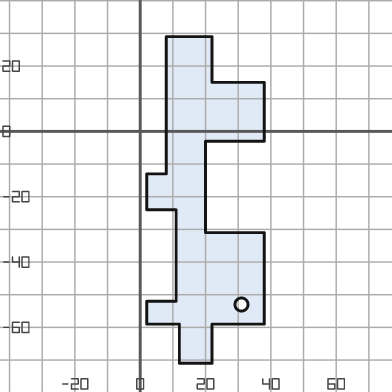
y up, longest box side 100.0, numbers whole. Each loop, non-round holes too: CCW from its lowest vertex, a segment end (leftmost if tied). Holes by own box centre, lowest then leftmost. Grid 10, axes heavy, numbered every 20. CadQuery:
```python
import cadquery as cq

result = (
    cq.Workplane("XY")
    .moveTo(12.0, -71.0)
    .lineTo(22.0, -71.0)
    .lineTo(22.0, -59.0)
    .lineTo(38.0, -59.0)
    .lineTo(38.0, -31.0)
    .lineTo(20.0, -31.0)
    .lineTo(20.0, -3.0)
    .lineTo(38.0, -3.0)
    .lineTo(38.0, 15.0)
    .lineTo(22.0, 15.0)
    .lineTo(22.0, 29.0)
    .lineTo(8.0, 29.0)
    .lineTo(8.0, -13.0)
    .lineTo(2.0, -13.0)
    .lineTo(2.0, -24.0)
    .lineTo(11.0, -24.0)
    .lineTo(11.0, -52.0)
    .lineTo(2.0, -52.0)
    .lineTo(2.0, -59.0)
    .lineTo(12.0, -59.0)
    .close()
    .moveTo(31.0, -53.0)
    .circle(2.0)
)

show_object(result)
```